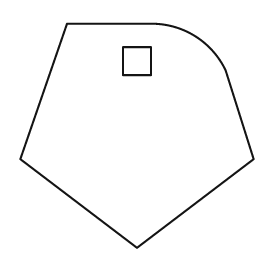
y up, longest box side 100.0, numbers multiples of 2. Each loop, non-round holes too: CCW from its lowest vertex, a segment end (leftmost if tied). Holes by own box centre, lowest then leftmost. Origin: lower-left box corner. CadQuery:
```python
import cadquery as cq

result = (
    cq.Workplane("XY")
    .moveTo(50.0, 0.0)
    .lineTo(100.0, 38.0)
    .lineTo(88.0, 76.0)
    .threePointArc((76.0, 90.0), (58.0, 96.0))
    .lineTo(20.0, 96.0)
    .lineTo(0.0, 38.0)
    .close()
    .moveTo(44.0, 74.0)
    .lineTo(56.0, 74.0)
    .lineTo(56.0, 86.0)
    .lineTo(44.0, 86.0)
    .close()
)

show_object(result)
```